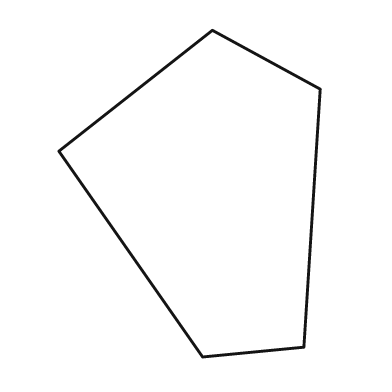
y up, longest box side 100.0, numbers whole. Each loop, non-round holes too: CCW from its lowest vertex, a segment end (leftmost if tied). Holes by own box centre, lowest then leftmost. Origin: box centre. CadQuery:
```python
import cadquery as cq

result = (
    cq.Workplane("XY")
    .moveTo(4.0, -50.0)
    .lineTo(35.0, -47.0)
    .lineTo(40.0, 32.0)
    .lineTo(7.0, 50.0)
    .lineTo(-40.0, 13.0)
    .close()
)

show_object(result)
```